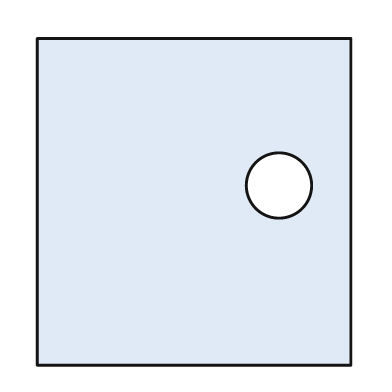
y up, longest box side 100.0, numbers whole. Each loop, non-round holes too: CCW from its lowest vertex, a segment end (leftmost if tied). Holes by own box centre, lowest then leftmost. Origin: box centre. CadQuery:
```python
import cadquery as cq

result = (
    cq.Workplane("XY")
    .moveTo(-48.0, -50.0)
    .lineTo(48.0, -50.0)
    .lineTo(48.0, 50.0)
    .lineTo(-48.0, 50.0)
    .close()
    .moveTo(26.0, 5.0)
    .circle(10.0)
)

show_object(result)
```